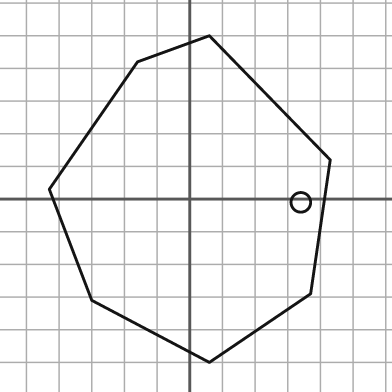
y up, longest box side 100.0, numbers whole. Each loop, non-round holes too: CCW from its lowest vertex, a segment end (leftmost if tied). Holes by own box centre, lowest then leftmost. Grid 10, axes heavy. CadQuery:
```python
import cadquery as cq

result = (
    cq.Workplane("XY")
    .moveTo(6.0, -50.0)
    .lineTo(37.0, -29.0)
    .lineTo(43.0, 12.0)
    .lineTo(6.0, 50.0)
    .lineTo(-16.0, 42.0)
    .lineTo(-43.0, 3.0)
    .lineTo(-30.0, -31.0)
    .close()
    .moveTo(34.0, -1.0)
    .circle(3.0)
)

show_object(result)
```